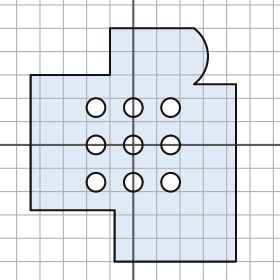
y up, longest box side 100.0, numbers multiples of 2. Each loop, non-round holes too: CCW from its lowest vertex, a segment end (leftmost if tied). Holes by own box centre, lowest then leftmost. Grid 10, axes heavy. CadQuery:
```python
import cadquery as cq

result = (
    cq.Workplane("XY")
    .moveTo(-8.0, -50.0)
    .lineTo(44.0, -50.0)
    .lineTo(44.0, 26.0)
    .lineTo(26.0, 26.0)
    .threePointArc((32.0, 38.0), (26.0, 50.0))
    .lineTo(-10.0, 50.0)
    .lineTo(-10.0, 30.0)
    .lineTo(-44.0, 30.0)
    .lineTo(-44.0, -28.0)
    .lineTo(-8.0, -28.0)
    .close()
    .moveTo(-16.0, -16.0)
    .circle(4.0)
    .moveTo(0.0, -16.0)
    .circle(4.0)
    .moveTo(16.0, -16.0)
    .circle(4.0)
    .moveTo(-16.0, 0.0)
    .circle(4.0)
    .moveTo(0.0, 0.0)
    .circle(4.0)
    .moveTo(16.0, 0.0)
    .circle(4.0)
    .moveTo(-16.0, 16.0)
    .circle(4.0)
    .moveTo(0.0, 16.0)
    .circle(4.0)
    .moveTo(16.0, 16.0)
    .circle(4.0)
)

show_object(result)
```